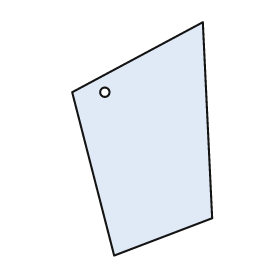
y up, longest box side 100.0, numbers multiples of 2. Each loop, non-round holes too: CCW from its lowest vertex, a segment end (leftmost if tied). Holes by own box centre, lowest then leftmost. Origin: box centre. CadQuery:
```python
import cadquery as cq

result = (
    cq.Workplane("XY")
    .moveTo(-12.0, -50.0)
    .lineTo(30.0, -34.0)
    .lineTo(26.0, 50.0)
    .lineTo(-30.0, 20.0)
    .close()
    .moveTo(-16.0, 20.0)
    .circle(2.0)
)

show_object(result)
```